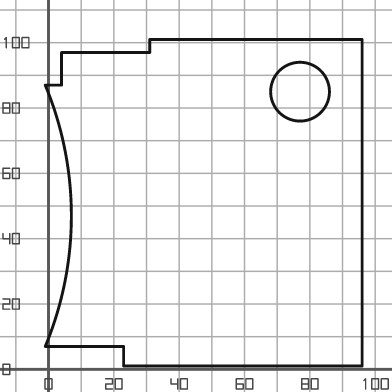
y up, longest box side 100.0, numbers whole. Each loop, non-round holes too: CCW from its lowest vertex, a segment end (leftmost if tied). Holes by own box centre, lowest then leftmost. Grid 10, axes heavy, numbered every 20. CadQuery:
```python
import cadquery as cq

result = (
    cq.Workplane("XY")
    .moveTo(23.0, 1.0)
    .lineTo(96.0, 1.0)
    .lineTo(96.0, 101.0)
    .lineTo(31.0, 101.0)
    .lineTo(31.0, 97.0)
    .lineTo(4.0, 97.0)
    .lineTo(4.0, 87.0)
    .lineTo(-1.0, 87.0)
    .threePointArc((7.0, 47.0), (-1.0, 7.0))
    .lineTo(23.0, 7.0)
    .close()
    .moveTo(77.0, 85.0)
    .circle(9.0)
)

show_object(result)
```